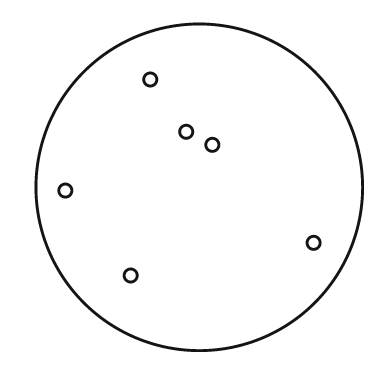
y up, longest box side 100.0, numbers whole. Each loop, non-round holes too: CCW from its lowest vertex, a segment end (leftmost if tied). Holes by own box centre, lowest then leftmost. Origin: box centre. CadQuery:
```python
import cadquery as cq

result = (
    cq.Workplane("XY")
    .moveTo(0.0, 0.0)
    .circle(50.0)
    .moveTo(-21.0, -27.0)
    .circle(2.0)
    .moveTo(35.0, -17.0)
    .circle(2.0)
    .moveTo(-41.0, -1.0)
    .circle(2.0)
    .moveTo(4.0, 13.0)
    .circle(2.0)
    .moveTo(-4.0, 17.0)
    .circle(2.0)
    .moveTo(-15.0, 33.0)
    .circle(2.0)
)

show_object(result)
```